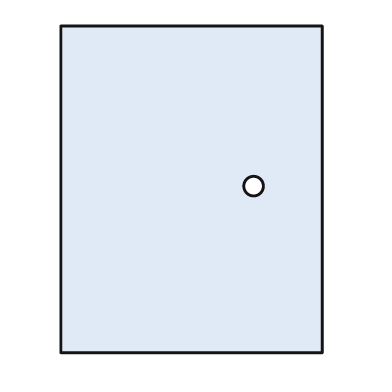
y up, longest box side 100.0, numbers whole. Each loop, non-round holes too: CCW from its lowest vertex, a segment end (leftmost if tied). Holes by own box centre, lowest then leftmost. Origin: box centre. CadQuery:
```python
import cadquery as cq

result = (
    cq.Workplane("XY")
    .moveTo(-40.0, -50.0)
    .lineTo(40.0, -50.0)
    .lineTo(40.0, 50.0)
    .lineTo(-40.0, 50.0)
    .close()
    .moveTo(19.0, 1.0)
    .circle(3.0)
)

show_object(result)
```